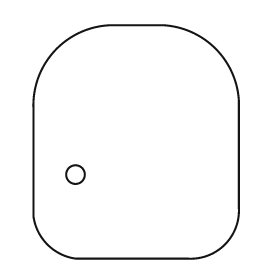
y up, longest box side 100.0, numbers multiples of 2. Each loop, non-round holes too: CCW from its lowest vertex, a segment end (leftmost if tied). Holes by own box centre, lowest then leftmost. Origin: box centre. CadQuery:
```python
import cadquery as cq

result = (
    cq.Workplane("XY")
    .moveTo(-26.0, -50.0)
    .lineTo(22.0, -50.0)
    .threePointArc((38.0, -44.0), (44.0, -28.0))
    .lineTo(44.0, 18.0)
    .threePointArc((34.0, 40.0), (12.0, 50.0))
    .lineTo(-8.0, 50.0)
    .threePointArc((-34.0, 40.0), (-44.0, 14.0))
    .lineTo(-44.0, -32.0)
    .threePointArc((-38.0, -44.0), (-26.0, -50.0))
    .close()
    .moveTo(-26.0, -14.0)
    .circle(4.0)
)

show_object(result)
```